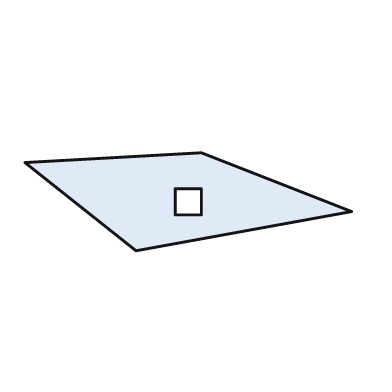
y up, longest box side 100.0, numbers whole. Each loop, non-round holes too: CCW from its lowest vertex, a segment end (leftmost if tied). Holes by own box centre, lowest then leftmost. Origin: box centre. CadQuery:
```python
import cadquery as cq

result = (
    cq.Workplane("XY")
    .moveTo(-16.0, -15.0)
    .lineTo(50.0, -3.0)
    .lineTo(4.0, 15.0)
    .lineTo(-50.0, 12.0)
    .close()
    .moveTo(-4.0, -4.0)
    .lineTo(4.0, -4.0)
    .lineTo(4.0, 4.0)
    .lineTo(-4.0, 4.0)
    .close()
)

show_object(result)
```